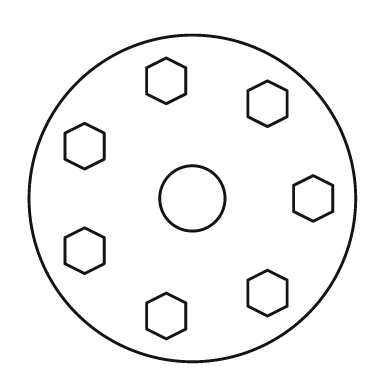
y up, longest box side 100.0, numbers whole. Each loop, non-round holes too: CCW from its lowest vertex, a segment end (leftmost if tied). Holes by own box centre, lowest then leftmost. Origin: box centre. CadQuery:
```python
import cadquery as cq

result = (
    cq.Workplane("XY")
    .moveTo(0.0, 0.0)
    .circle(50.0)
    .moveTo(-8.0, -43.0)
    .lineTo(-2.0, -40.0)
    .lineTo(-2.0, -32.0)
    .lineTo(-8.0, -29.0)
    .lineTo(-14.0, -32.0)
    .lineTo(-14.0, -40.0)
    .close()
    .moveTo(23.0, -36.0)
    .lineTo(29.0, -33.0)
    .lineTo(29.0, -25.0)
    .lineTo(23.0, -22.0)
    .lineTo(17.0, -25.0)
    .lineTo(17.0, -33.0)
    .close()
    .moveTo(-33.0, -23.0)
    .lineTo(-27.0, -20.0)
    .lineTo(-27.0, -12.0)
    .lineTo(-33.0, -9.0)
    .lineTo(-39.0, -12.0)
    .lineTo(-39.0, -20.0)
    .close()
    .moveTo(0.0, 0.0)
    .circle(10.0)
    .moveTo(37.0, -7.0)
    .lineTo(43.0, -4.0)
    .lineTo(43.0, 4.0)
    .lineTo(37.0, 7.0)
    .lineTo(31.0, 4.0)
    .lineTo(31.0, -4.0)
    .close()
    .moveTo(-33.0, 9.0)
    .lineTo(-27.0, 12.0)
    .lineTo(-27.0, 20.0)
    .lineTo(-33.0, 23.0)
    .lineTo(-39.0, 20.0)
    .lineTo(-39.0, 12.0)
    .close()
    .moveTo(23.0, 22.0)
    .lineTo(29.0, 25.0)
    .lineTo(29.0, 33.0)
    .lineTo(23.0, 36.0)
    .lineTo(17.0, 33.0)
    .lineTo(17.0, 25.0)
    .close()
    .moveTo(-8.0, 29.0)
    .lineTo(-2.0, 32.0)
    .lineTo(-2.0, 40.0)
    .lineTo(-8.0, 43.0)
    .lineTo(-14.0, 40.0)
    .lineTo(-14.0, 32.0)
    .close()
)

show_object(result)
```